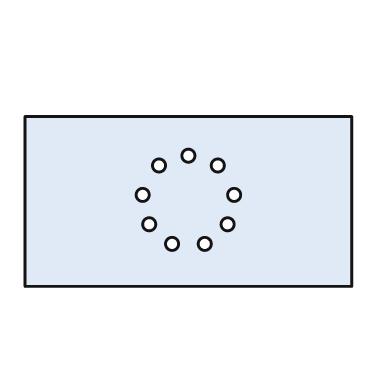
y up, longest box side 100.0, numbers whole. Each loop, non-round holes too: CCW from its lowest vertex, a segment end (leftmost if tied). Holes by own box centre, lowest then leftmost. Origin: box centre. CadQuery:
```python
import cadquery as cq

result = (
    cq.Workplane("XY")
    .moveTo(-50.0, -26.0)
    .lineTo(50.0, -26.0)
    .lineTo(50.0, 26.0)
    .lineTo(-50.0, 26.0)
    .close()
    .moveTo(-5.0, -13.0)
    .circle(2.0)
    .moveTo(5.0, -13.0)
    .circle(2.0)
    .moveTo(-12.0, -7.0)
    .circle(2.0)
    .moveTo(12.0, -7.0)
    .circle(2.0)
    .moveTo(-14.0, 2.0)
    .circle(2.0)
    .moveTo(14.0, 2.0)
    .circle(2.0)
    .moveTo(-9.0, 11.0)
    .circle(2.0)
    .moveTo(9.0, 11.0)
    .circle(2.0)
    .moveTo(0.0, 14.0)
    .circle(2.0)
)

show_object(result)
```